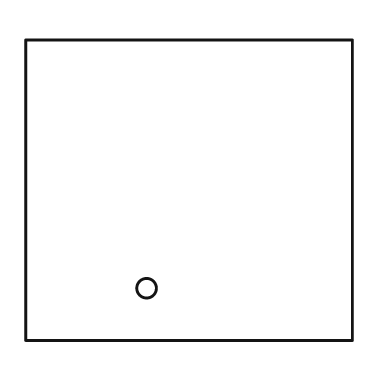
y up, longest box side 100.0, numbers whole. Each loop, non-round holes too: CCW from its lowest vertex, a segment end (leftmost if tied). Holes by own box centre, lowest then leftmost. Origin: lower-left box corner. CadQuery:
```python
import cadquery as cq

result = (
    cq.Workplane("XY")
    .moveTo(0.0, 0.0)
    .lineTo(100.0, 0.0)
    .lineTo(100.0, 92.0)
    .lineTo(0.0, 92.0)
    .close()
    .moveTo(37.0, 16.0)
    .circle(3.0)
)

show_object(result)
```